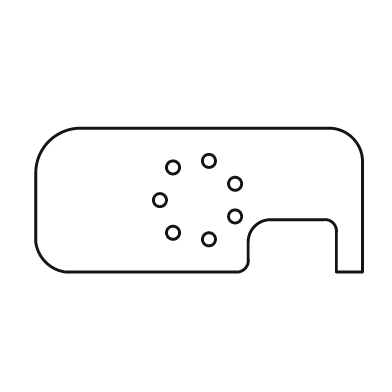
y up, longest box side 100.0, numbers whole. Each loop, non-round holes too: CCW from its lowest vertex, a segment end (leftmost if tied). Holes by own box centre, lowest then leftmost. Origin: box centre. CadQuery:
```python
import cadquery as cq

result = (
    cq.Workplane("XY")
    .moveTo(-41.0, -22.0)
    .lineTo(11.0, -22.0)
    .threePointArc((14.0, -21.0), (15.0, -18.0))
    .lineTo(15.0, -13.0)
    .threePointArc((17.0, -8.0), (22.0, -6.0))
    .lineTo(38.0, -6.0)
    .threePointArc((41.0, -7.0), (42.0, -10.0))
    .lineTo(42.0, -22.0)
    .lineTo(50.0, -22.0)
    .lineTo(50.0, 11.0)
    .threePointArc((47.0, 19.0), (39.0, 22.0))
    .lineTo(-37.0, 22.0)
    .threePointArc((-46.0, 18.0), (-50.0, 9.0))
    .lineTo(-50.0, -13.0)
    .threePointArc((-47.0, -19.0), (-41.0, -22.0))
    .close()
    .moveTo(3.0, -12.0)
    .circle(2.0)
    .moveTo(-8.0, -10.0)
    .circle(2.0)
    .moveTo(11.0, -5.0)
    .circle(2.0)
    .moveTo(-12.0, 0.0)
    .circle(2.0)
    .moveTo(11.0, 5.0)
    .circle(2.0)
    .moveTo(-8.0, 10.0)
    .circle(2.0)
    .moveTo(3.0, 12.0)
    .circle(2.0)
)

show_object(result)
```